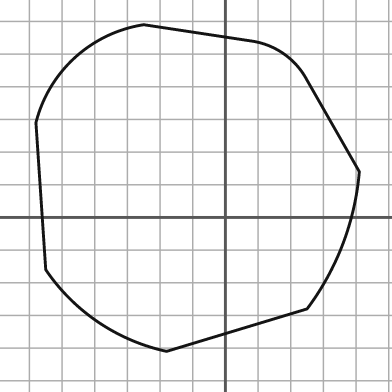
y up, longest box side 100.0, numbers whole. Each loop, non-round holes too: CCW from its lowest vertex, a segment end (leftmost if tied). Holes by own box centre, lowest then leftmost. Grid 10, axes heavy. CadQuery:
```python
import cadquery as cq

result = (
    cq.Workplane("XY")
    .moveTo(-18.0, -41.0)
    .lineTo(25.0, -28.0)
    .threePointArc((36.0, -8.0), (41.0, 14.0))
    .lineTo(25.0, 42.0)
    .threePointArc((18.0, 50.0), (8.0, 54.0))
    .lineTo(-25.0, 59.0)
    .threePointArc((-46.0, 49.0), (-58.0, 29.0))
    .lineTo(-55.0, -16.0)
    .threePointArc((-39.0, -32.0), (-18.0, -41.0))
    .close()
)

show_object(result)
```